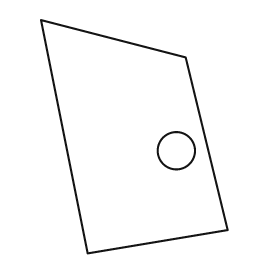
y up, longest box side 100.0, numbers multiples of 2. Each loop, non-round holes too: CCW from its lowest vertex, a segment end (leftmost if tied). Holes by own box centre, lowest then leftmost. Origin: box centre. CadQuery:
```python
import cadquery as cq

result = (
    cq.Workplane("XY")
    .moveTo(-20.0, -50.0)
    .lineTo(40.0, -40.0)
    .lineTo(22.0, 34.0)
    .lineTo(-40.0, 50.0)
    .close()
    .moveTo(18.0, -6.0)
    .circle(8.0)
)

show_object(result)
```